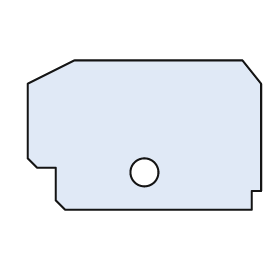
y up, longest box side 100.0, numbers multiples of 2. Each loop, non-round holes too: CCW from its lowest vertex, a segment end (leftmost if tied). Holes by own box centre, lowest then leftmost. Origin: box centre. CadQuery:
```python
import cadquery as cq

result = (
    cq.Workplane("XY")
    .moveTo(-34.0, -32.0)
    .lineTo(46.0, -32.0)
    .lineTo(46.0, -24.0)
    .lineTo(50.0, -24.0)
    .lineTo(50.0, 22.0)
    .lineTo(42.0, 32.0)
    .lineTo(-30.0, 32.0)
    .lineTo(-50.0, 22.0)
    .lineTo(-50.0, -10.0)
    .lineTo(-46.0, -14.0)
    .lineTo(-38.0, -14.0)
    .lineTo(-38.0, -28.0)
    .close()
    .moveTo(0.0, -16.0)
    .circle(6.0)
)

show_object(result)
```